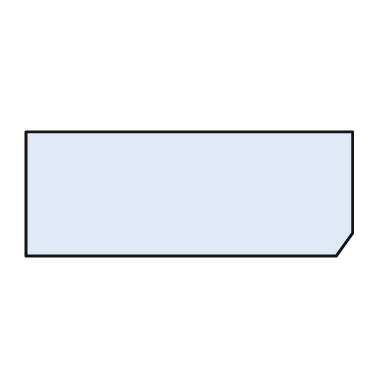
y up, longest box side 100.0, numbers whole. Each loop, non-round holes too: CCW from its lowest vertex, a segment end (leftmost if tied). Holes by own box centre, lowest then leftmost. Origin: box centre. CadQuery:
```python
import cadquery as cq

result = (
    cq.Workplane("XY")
    .moveTo(-50.0, -19.0)
    .lineTo(45.0, -19.0)
    .lineTo(50.0, -12.0)
    .lineTo(50.0, 19.0)
    .lineTo(-50.0, 19.0)
    .close()
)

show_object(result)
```